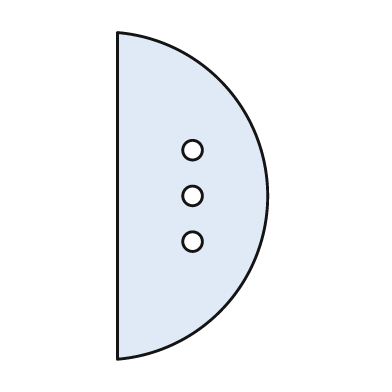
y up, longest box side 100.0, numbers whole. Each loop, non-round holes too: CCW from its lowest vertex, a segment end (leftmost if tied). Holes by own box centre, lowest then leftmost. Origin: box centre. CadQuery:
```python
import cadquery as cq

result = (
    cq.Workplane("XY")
    .moveTo(-23.0, -50.0)
    .threePointArc((23.0, 0.0), (-23.0, 50.0))
    .close()
    .moveTo(0.0, -14.0)
    .circle(3.0)
    .moveTo(0.0, 0.0)
    .circle(3.0)
    .moveTo(0.0, 14.0)
    .circle(3.0)
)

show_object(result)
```